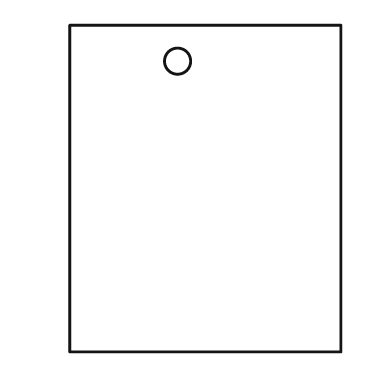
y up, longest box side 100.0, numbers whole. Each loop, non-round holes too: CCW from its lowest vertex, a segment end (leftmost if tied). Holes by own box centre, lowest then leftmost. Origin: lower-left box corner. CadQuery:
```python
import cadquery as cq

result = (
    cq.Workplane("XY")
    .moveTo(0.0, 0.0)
    .lineTo(83.0, 0.0)
    .lineTo(83.0, 100.0)
    .lineTo(0.0, 100.0)
    .close()
    .moveTo(33.0, 89.0)
    .circle(4.0)
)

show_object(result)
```